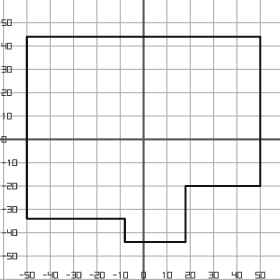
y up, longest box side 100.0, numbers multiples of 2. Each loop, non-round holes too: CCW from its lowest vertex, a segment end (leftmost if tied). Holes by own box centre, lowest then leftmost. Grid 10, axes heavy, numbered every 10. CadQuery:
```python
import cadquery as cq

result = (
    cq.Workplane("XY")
    .moveTo(-8.0, -44.0)
    .lineTo(18.0, -44.0)
    .lineTo(18.0, -20.0)
    .lineTo(50.0, -20.0)
    .lineTo(50.0, 44.0)
    .lineTo(-50.0, 44.0)
    .lineTo(-50.0, -34.0)
    .lineTo(-8.0, -34.0)
    .close()
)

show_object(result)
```